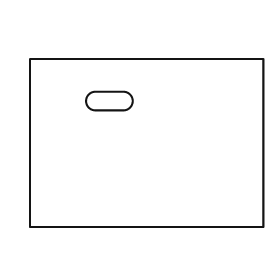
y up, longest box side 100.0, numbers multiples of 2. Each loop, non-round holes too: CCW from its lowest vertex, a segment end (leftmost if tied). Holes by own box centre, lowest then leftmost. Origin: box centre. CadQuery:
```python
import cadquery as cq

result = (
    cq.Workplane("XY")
    .moveTo(-50.0, -36.0)
    .lineTo(50.0, -36.0)
    .lineTo(50.0, 36.0)
    .lineTo(-50.0, 36.0)
    .close()
    .moveTo(-22.0, 14.0)
    .lineTo(-10.0, 14.0)
    .threePointArc((-6.0, 18.0), (-10.0, 22.0))
    .lineTo(-22.0, 22.0)
    .threePointArc((-26.0, 18.0), (-22.0, 14.0))
    .close()
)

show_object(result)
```